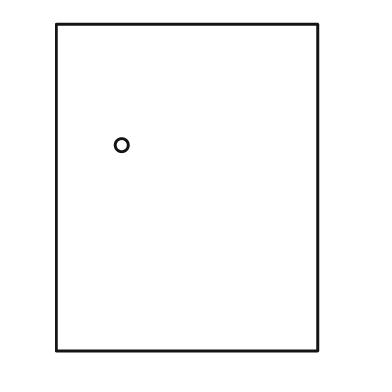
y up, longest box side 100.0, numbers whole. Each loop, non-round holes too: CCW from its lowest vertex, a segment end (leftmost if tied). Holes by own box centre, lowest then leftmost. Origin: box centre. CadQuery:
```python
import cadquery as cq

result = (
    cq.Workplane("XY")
    .moveTo(-40.0, -50.0)
    .lineTo(40.0, -50.0)
    .lineTo(40.0, 50.0)
    .lineTo(-40.0, 50.0)
    .close()
    .moveTo(-20.0, 13.0)
    .circle(2.0)
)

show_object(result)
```